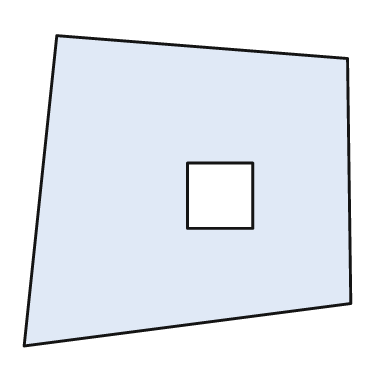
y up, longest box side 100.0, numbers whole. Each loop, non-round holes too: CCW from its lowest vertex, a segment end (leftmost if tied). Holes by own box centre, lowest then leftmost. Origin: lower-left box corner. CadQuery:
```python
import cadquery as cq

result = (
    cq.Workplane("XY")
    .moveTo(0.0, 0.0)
    .lineTo(100.0, 13.0)
    .lineTo(99.0, 88.0)
    .lineTo(10.0, 95.0)
    .close()
    .moveTo(50.0, 36.0)
    .lineTo(70.0, 36.0)
    .lineTo(70.0, 56.0)
    .lineTo(50.0, 56.0)
    .close()
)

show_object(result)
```